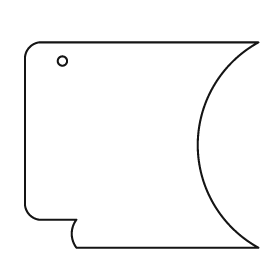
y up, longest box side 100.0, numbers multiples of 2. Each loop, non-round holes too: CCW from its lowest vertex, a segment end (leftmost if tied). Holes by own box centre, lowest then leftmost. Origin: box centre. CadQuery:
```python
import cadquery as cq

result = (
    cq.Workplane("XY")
    .moveTo(-28.0, -44.0)
    .lineTo(50.0, -44.0)
    .threePointArc((24.0, 0.0), (50.0, 44.0))
    .lineTo(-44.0, 44.0)
    .threePointArc((-48.0, 42.0), (-50.0, 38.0))
    .lineTo(-50.0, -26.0)
    .threePointArc((-48.0, -30.0), (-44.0, -32.0))
    .lineTo(-28.0, -32.0)
    .threePointArc((-30.0, -38.0), (-28.0, -44.0))
    .close()
    .moveTo(-34.0, 36.0)
    .circle(2.0)
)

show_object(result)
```